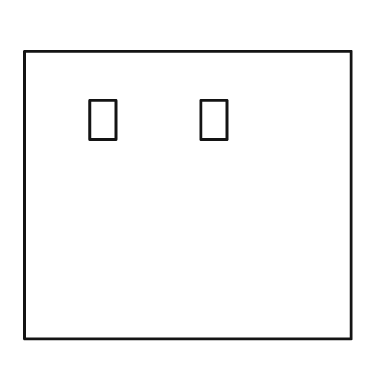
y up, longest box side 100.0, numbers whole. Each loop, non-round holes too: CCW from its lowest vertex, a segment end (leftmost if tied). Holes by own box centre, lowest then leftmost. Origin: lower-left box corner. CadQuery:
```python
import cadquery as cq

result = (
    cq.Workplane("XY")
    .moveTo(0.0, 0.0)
    .lineTo(100.0, 0.0)
    .lineTo(100.0, 88.0)
    .lineTo(0.0, 88.0)
    .close()
    .moveTo(20.0, 61.0)
    .lineTo(28.0, 61.0)
    .lineTo(28.0, 73.0)
    .lineTo(20.0, 73.0)
    .close()
    .moveTo(54.0, 61.0)
    .lineTo(62.0, 61.0)
    .lineTo(62.0, 73.0)
    .lineTo(54.0, 73.0)
    .close()
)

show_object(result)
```